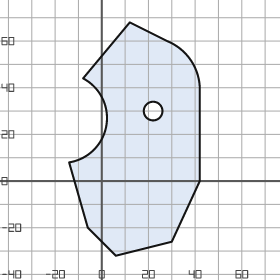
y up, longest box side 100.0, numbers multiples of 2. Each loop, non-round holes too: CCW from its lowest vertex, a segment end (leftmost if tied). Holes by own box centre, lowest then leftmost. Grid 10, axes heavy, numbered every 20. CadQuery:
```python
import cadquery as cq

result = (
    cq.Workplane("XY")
    .moveTo(6.0, -32.0)
    .lineTo(30.0, -26.0)
    .lineTo(42.0, 0.0)
    .lineTo(42.0, 40.0)
    .threePointArc((38.0, 52.0), (28.0, 60.0))
    .lineTo(12.0, 68.0)
    .lineTo(-8.0, 44.0)
    .threePointArc((2.0, 24.0), (-14.0, 8.0))
    .lineTo(-6.0, -20.0)
    .close()
    .moveTo(22.0, 30.0)
    .circle(4.0)
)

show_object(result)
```